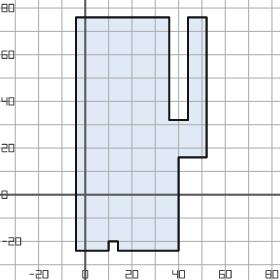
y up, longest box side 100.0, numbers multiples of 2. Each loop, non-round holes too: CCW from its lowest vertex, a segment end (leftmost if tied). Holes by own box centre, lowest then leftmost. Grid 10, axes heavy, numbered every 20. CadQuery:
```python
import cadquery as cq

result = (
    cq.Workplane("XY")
    .moveTo(-4.0, -24.0)
    .lineTo(10.0, -24.0)
    .lineTo(10.0, -20.0)
    .lineTo(14.0, -20.0)
    .lineTo(14.0, -24.0)
    .lineTo(40.0, -24.0)
    .lineTo(40.0, 16.0)
    .lineTo(52.0, 16.0)
    .lineTo(52.0, 76.0)
    .lineTo(44.0, 76.0)
    .lineTo(44.0, 32.0)
    .lineTo(36.0, 32.0)
    .lineTo(36.0, 76.0)
    .lineTo(-4.0, 76.0)
    .close()
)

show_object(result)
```